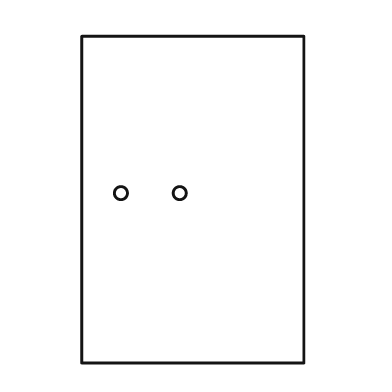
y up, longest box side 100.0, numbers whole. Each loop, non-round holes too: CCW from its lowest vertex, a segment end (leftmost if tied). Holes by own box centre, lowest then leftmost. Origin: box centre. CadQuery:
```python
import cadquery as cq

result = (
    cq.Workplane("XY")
    .moveTo(-34.0, -50.0)
    .lineTo(34.0, -50.0)
    .lineTo(34.0, 50.0)
    .lineTo(-34.0, 50.0)
    .close()
    .moveTo(-22.0, 2.0)
    .circle(2.0)
    .moveTo(-4.0, 2.0)
    .circle(2.0)
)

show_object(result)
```